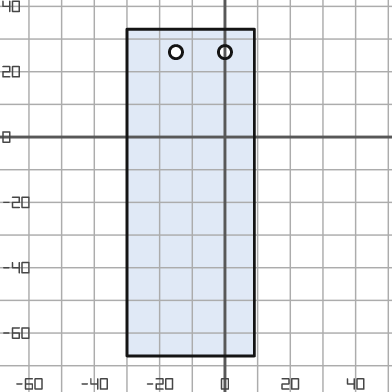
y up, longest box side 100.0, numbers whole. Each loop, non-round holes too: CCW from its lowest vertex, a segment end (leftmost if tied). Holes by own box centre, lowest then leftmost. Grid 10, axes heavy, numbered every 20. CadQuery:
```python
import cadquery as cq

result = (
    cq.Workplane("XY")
    .moveTo(-30.0, -67.0)
    .lineTo(9.0, -67.0)
    .lineTo(9.0, 33.0)
    .lineTo(-30.0, 33.0)
    .close()
    .moveTo(-15.0, 26.0)
    .circle(2.0)
    .moveTo(0.0, 26.0)
    .circle(2.0)
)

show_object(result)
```